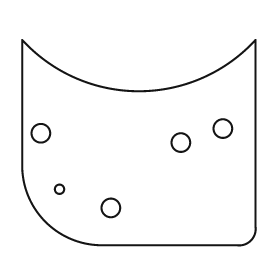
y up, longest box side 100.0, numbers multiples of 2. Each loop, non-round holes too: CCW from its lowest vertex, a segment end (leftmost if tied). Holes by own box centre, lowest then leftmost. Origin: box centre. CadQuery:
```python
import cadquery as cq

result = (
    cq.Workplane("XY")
    .moveTo(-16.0, -44.0)
    .lineTo(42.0, -44.0)
    .threePointArc((48.0, -42.0), (50.0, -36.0))
    .lineTo(50.0, 44.0)
    .threePointArc((0.0, 22.0), (-50.0, 44.0))
    .lineTo(-50.0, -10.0)
    .threePointArc((-40.0, -34.0), (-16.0, -44.0))
    .close()
    .moveTo(-12.0, -28.0)
    .circle(4.0)
    .moveTo(-34.0, -20.0)
    .circle(2.0)
    .moveTo(18.0, 0.0)
    .circle(4.0)
    .moveTo(-42.0, 4.0)
    .circle(4.0)
    .moveTo(36.0, 6.0)
    .circle(4.0)
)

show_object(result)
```